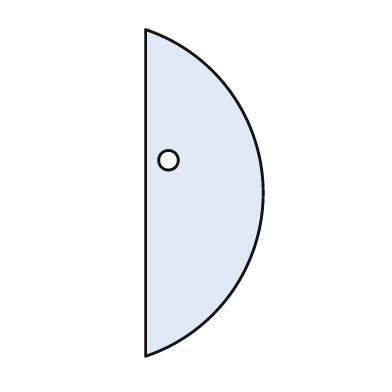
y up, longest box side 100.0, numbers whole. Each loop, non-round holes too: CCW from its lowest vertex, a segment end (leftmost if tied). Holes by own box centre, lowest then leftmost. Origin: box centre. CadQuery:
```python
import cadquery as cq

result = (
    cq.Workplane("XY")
    .moveTo(-18.0, -50.0)
    .threePointArc((18.0, 0.0), (-18.0, 50.0))
    .close()
    .moveTo(-11.0, 10.0)
    .circle(3.0)
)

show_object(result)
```